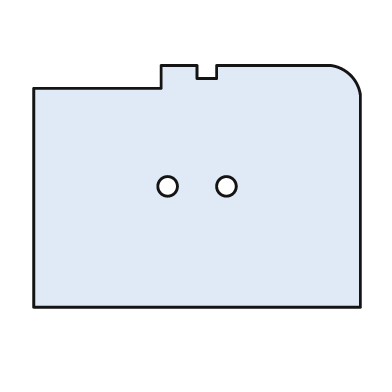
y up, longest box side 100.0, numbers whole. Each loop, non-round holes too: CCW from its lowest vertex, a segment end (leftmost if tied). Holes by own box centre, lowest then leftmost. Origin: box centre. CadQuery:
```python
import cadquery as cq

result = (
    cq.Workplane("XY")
    .moveTo(-50.0, -37.0)
    .lineTo(50.0, -37.0)
    .lineTo(50.0, 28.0)
    .threePointArc((47.0, 34.0), (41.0, 37.0))
    .lineTo(6.0, 37.0)
    .lineTo(6.0, 33.0)
    .lineTo(0.0, 33.0)
    .lineTo(0.0, 37.0)
    .lineTo(-11.0, 37.0)
    .lineTo(-11.0, 30.0)
    .lineTo(-50.0, 30.0)
    .close()
    .moveTo(-9.0, 0.0)
    .circle(3.0)
    .moveTo(9.0, 0.0)
    .circle(3.0)
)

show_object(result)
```